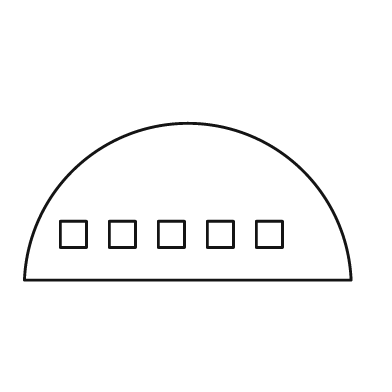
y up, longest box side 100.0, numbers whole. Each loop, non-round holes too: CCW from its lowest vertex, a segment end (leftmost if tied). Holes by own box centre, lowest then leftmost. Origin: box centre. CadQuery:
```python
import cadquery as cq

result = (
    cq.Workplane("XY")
    .moveTo(-50.0, -24.0)
    .lineTo(50.0, -24.0)
    .threePointArc((0.0, 24.0), (-50.0, -24.0))
    .close()
    .moveTo(-39.0, -14.0)
    .lineTo(-31.0, -14.0)
    .lineTo(-31.0, -6.0)
    .lineTo(-39.0, -6.0)
    .close()
    .moveTo(-24.0, -14.0)
    .lineTo(-16.0, -14.0)
    .lineTo(-16.0, -6.0)
    .lineTo(-24.0, -6.0)
    .close()
    .moveTo(-9.0, -14.0)
    .lineTo(-1.0, -14.0)
    .lineTo(-1.0, -6.0)
    .lineTo(-9.0, -6.0)
    .close()
    .moveTo(6.0, -14.0)
    .lineTo(14.0, -14.0)
    .lineTo(14.0, -6.0)
    .lineTo(6.0, -6.0)
    .close()
    .moveTo(21.0, -14.0)
    .lineTo(29.0, -14.0)
    .lineTo(29.0, -6.0)
    .lineTo(21.0, -6.0)
    .close()
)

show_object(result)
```